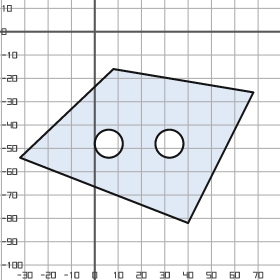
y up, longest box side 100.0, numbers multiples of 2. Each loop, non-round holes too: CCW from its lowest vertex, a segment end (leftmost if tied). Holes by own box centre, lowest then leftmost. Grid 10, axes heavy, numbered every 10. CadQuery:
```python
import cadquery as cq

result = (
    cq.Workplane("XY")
    .moveTo(40.0, -82.0)
    .lineTo(68.0, -26.0)
    .lineTo(8.0, -16.0)
    .lineTo(-32.0, -54.0)
    .close()
    .moveTo(6.0, -48.0)
    .circle(6.0)
    .moveTo(32.0, -48.0)
    .circle(6.0)
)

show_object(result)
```